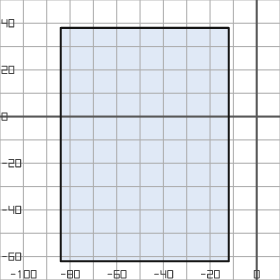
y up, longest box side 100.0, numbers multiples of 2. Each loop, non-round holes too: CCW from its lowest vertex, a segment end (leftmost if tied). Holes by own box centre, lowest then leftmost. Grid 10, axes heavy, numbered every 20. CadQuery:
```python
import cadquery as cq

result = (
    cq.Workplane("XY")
    .moveTo(-84.0, -62.0)
    .lineTo(-12.0, -62.0)
    .lineTo(-12.0, 38.0)
    .lineTo(-84.0, 38.0)
    .close()
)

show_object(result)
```